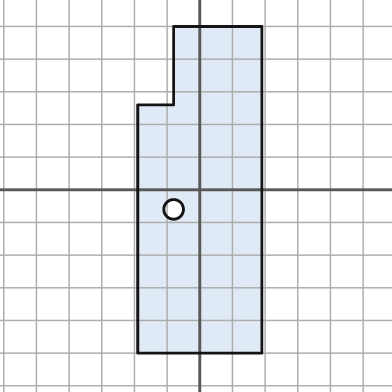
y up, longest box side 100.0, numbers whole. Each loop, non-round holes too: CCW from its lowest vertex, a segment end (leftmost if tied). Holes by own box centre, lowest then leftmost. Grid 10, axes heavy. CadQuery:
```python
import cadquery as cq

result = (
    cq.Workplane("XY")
    .moveTo(-19.0, -50.0)
    .lineTo(19.0, -50.0)
    .lineTo(19.0, 50.0)
    .lineTo(-8.0, 50.0)
    .lineTo(-8.0, 26.0)
    .lineTo(-19.0, 26.0)
    .close()
    .moveTo(-8.0, -6.0)
    .circle(3.0)
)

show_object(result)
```